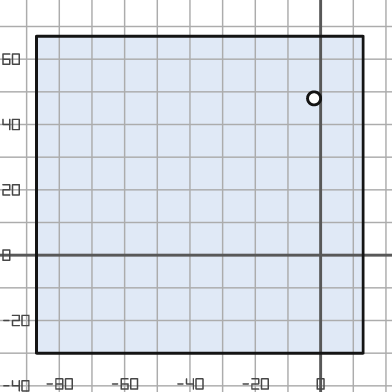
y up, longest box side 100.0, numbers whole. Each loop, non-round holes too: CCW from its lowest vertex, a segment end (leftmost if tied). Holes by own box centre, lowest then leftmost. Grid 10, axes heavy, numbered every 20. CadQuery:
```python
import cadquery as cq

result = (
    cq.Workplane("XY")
    .moveTo(-87.0, -30.0)
    .lineTo(13.0, -30.0)
    .lineTo(13.0, 67.0)
    .lineTo(-87.0, 67.0)
    .close()
    .moveTo(-2.0, 48.0)
    .circle(2.0)
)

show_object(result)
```